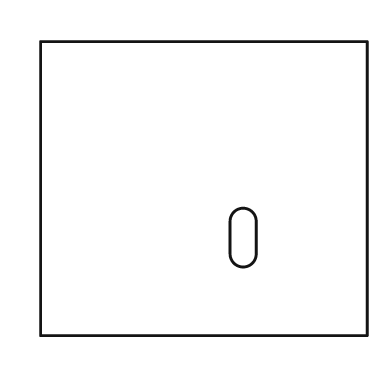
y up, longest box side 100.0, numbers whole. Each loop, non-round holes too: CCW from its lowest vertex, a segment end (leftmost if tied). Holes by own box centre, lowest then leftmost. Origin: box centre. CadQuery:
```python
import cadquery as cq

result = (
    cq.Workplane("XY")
    .moveTo(-50.0, -45.0)
    .lineTo(50.0, -45.0)
    .lineTo(50.0, 45.0)
    .lineTo(-50.0, 45.0)
    .close()
    .moveTo(8.0, -20.0)
    .threePointArc((12.0, -24.0), (16.0, -20.0))
    .lineTo(16.0, -10.0)
    .threePointArc((12.0, -6.0), (8.0, -10.0))
    .close()
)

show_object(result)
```